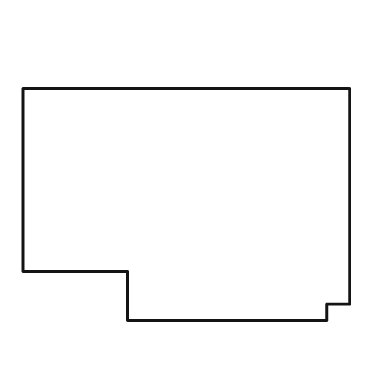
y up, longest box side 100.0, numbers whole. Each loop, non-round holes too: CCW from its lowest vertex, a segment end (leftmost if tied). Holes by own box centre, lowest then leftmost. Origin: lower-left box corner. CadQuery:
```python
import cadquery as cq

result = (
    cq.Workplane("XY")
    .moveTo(32.0, 0.0)
    .lineTo(93.0, 0.0)
    .lineTo(93.0, 5.0)
    .lineTo(100.0, 5.0)
    .lineTo(100.0, 71.0)
    .lineTo(0.0, 71.0)
    .lineTo(0.0, 15.0)
    .lineTo(32.0, 15.0)
    .close()
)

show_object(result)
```